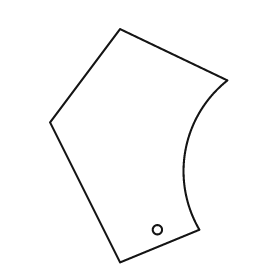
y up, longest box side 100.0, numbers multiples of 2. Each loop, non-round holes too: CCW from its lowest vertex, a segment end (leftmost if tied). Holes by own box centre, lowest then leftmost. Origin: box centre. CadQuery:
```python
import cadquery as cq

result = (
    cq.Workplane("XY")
    .moveTo(-8.0, -50.0)
    .lineTo(26.0, -36.0)
    .threePointArc((20.0, -2.0), (38.0, 28.0))
    .lineTo(-8.0, 50.0)
    .lineTo(-38.0, 10.0)
    .close()
    .moveTo(8.0, -36.0)
    .circle(2.0)
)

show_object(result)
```